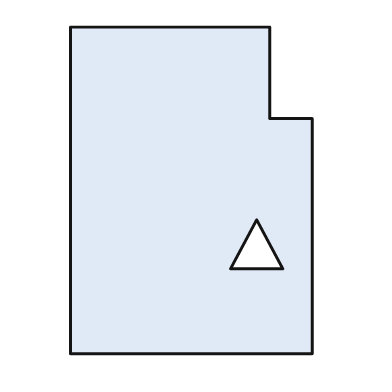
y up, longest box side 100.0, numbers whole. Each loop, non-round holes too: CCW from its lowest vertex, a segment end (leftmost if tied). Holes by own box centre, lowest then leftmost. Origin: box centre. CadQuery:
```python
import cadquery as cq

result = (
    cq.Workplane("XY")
    .moveTo(-37.0, -50.0)
    .lineTo(37.0, -50.0)
    .lineTo(37.0, 22.0)
    .lineTo(24.0, 22.0)
    .lineTo(24.0, 50.0)
    .lineTo(-37.0, 50.0)
    .close()
    .moveTo(12.0, -24.0)
    .lineTo(28.0, -24.0)
    .lineTo(20.0, -9.0)
    .close()
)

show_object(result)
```